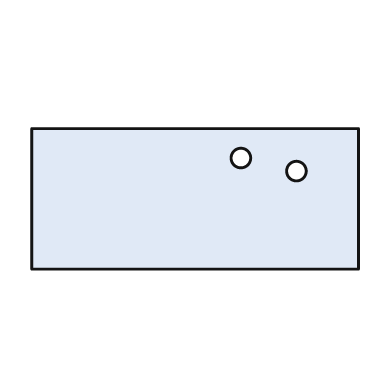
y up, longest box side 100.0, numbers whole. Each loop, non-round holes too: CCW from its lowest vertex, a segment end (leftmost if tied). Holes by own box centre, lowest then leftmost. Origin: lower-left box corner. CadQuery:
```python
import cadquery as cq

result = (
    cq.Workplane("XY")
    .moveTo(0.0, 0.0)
    .lineTo(100.0, 0.0)
    .lineTo(100.0, 43.0)
    .lineTo(0.0, 43.0)
    .close()
    .moveTo(81.0, 30.0)
    .circle(3.0)
    .moveTo(64.0, 34.0)
    .circle(3.0)
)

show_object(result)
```